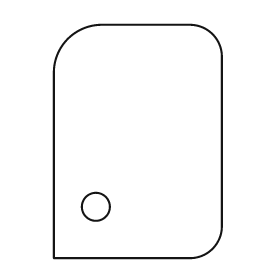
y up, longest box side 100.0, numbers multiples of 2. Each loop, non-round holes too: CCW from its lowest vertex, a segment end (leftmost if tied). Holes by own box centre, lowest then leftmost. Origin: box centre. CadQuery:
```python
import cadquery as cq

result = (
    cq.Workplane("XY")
    .moveTo(-36.0, -50.0)
    .lineTo(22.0, -50.0)
    .threePointArc((32.0, -46.0), (36.0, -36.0))
    .lineTo(36.0, 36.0)
    .threePointArc((32.0, 46.0), (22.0, 50.0))
    .lineTo(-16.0, 50.0)
    .threePointArc((-30.0, 44.0), (-36.0, 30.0))
    .close()
    .moveTo(-18.0, -28.0)
    .circle(6.0)
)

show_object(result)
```